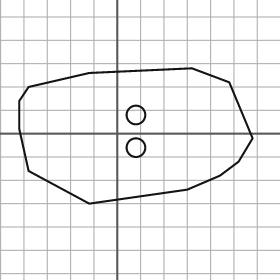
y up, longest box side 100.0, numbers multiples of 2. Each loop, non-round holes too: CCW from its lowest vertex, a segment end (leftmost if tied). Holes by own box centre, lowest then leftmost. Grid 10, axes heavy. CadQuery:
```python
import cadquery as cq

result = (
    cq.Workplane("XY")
    .moveTo(-12.0, -30.0)
    .lineTo(30.0, -24.0)
    .lineTo(44.0, -18.0)
    .lineTo(52.0, -12.0)
    .lineTo(58.0, -2.0)
    .lineTo(48.0, 22.0)
    .lineTo(32.0, 28.0)
    .lineTo(-12.0, 26.0)
    .lineTo(-38.0, 20.0)
    .lineTo(-42.0, 14.0)
    .lineTo(-42.0, 2.0)
    .lineTo(-38.0, -16.0)
    .close()
    .moveTo(8.0, -6.0)
    .circle(4.0)
    .moveTo(8.0, 8.0)
    .circle(4.0)
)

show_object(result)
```